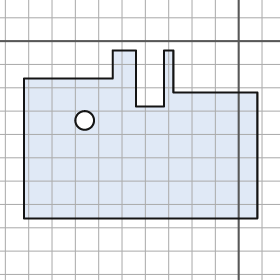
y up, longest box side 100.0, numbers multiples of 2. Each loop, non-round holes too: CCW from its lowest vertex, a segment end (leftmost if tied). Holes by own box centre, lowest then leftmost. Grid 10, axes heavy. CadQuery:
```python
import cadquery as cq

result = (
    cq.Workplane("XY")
    .moveTo(-92.0, -76.0)
    .lineTo(8.0, -76.0)
    .lineTo(8.0, -22.0)
    .lineTo(-28.0, -22.0)
    .lineTo(-28.0, -4.0)
    .lineTo(-32.0, -4.0)
    .lineTo(-32.0, -28.0)
    .lineTo(-44.0, -28.0)
    .lineTo(-44.0, -4.0)
    .lineTo(-54.0, -4.0)
    .lineTo(-54.0, -16.0)
    .lineTo(-92.0, -16.0)
    .close()
    .moveTo(-66.0, -34.0)
    .circle(4.0)
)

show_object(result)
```